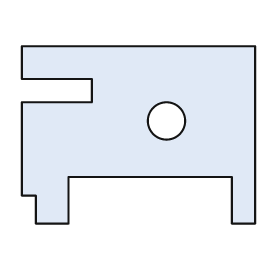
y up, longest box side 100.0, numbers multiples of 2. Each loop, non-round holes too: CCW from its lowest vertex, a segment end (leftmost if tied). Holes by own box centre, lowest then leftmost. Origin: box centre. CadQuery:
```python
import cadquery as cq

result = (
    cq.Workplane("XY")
    .moveTo(-44.0, -38.0)
    .lineTo(-30.0, -38.0)
    .lineTo(-30.0, -18.0)
    .lineTo(40.0, -18.0)
    .lineTo(40.0, -38.0)
    .lineTo(50.0, -38.0)
    .lineTo(50.0, 38.0)
    .lineTo(-50.0, 38.0)
    .lineTo(-50.0, 24.0)
    .lineTo(-20.0, 24.0)
    .lineTo(-20.0, 14.0)
    .lineTo(-50.0, 14.0)
    .lineTo(-50.0, -26.0)
    .lineTo(-44.0, -26.0)
    .close()
    .moveTo(12.0, 6.0)
    .circle(8.0)
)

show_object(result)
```